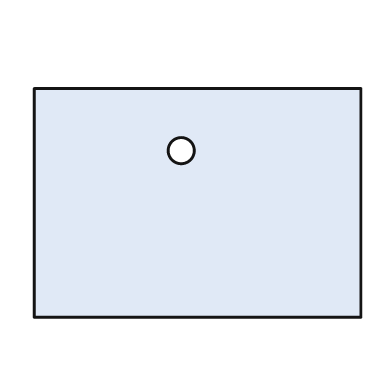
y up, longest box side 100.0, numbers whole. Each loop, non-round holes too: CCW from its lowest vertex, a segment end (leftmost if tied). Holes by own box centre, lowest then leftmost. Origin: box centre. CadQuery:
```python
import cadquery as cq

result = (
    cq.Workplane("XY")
    .moveTo(-50.0, -35.0)
    .lineTo(50.0, -35.0)
    .lineTo(50.0, 35.0)
    .lineTo(-50.0, 35.0)
    .close()
    .moveTo(-5.0, 16.0)
    .circle(4.0)
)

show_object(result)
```